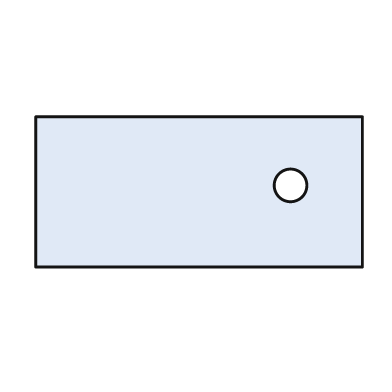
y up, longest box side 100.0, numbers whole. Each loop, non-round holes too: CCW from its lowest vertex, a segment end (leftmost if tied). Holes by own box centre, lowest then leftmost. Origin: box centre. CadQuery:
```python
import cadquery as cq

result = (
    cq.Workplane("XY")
    .moveTo(-50.0, -23.0)
    .lineTo(50.0, -23.0)
    .lineTo(50.0, 23.0)
    .lineTo(-50.0, 23.0)
    .close()
    .moveTo(28.0, 2.0)
    .circle(5.0)
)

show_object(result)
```